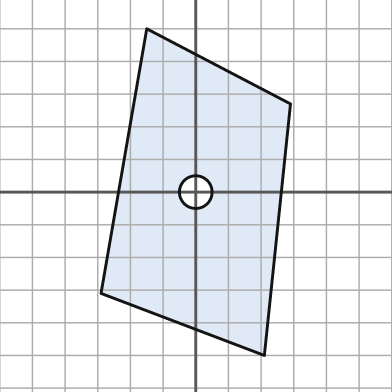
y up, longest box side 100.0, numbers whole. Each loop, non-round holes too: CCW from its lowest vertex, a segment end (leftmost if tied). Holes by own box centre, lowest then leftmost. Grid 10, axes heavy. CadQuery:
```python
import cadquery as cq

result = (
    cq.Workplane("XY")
    .moveTo(21.0, -50.0)
    .lineTo(29.0, 27.0)
    .lineTo(-15.0, 50.0)
    .lineTo(-29.0, -31.0)
    .close()
    .moveTo(0.0, 0.0)
    .circle(5.0)
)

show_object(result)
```